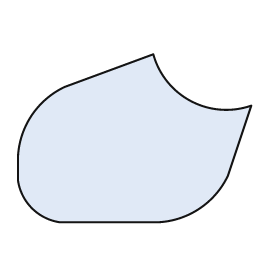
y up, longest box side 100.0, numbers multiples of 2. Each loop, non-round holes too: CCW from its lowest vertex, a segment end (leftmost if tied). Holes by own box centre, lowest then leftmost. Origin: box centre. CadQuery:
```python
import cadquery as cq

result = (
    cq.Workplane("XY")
    .moveTo(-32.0, -36.0)
    .lineTo(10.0, -36.0)
    .threePointArc((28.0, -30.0), (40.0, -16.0))
    .lineTo(50.0, 14.0)
    .threePointArc((24.0, 16.0), (8.0, 36.0))
    .lineTo(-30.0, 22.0)
    .threePointArc((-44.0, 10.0), (-50.0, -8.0))
    .lineTo(-50.0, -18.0)
    .threePointArc((-44.0, -30.0), (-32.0, -36.0))
    .close()
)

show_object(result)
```